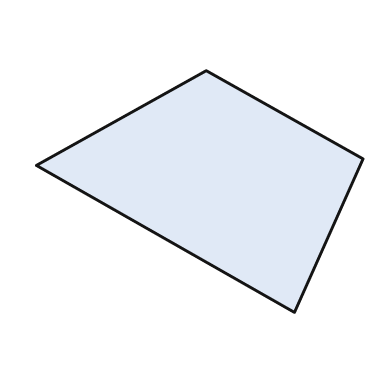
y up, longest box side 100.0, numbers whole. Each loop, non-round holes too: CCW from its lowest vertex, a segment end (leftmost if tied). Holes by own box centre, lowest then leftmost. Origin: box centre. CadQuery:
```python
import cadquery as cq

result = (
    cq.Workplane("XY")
    .moveTo(29.0, -37.0)
    .lineTo(50.0, 10.0)
    .lineTo(2.0, 37.0)
    .lineTo(-50.0, 8.0)
    .close()
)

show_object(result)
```